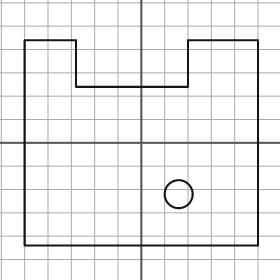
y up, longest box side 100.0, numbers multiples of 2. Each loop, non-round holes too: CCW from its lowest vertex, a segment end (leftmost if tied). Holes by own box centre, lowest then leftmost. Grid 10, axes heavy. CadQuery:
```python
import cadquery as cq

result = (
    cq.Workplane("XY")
    .moveTo(-50.0, -44.0)
    .lineTo(50.0, -44.0)
    .lineTo(50.0, 44.0)
    .lineTo(20.0, 44.0)
    .lineTo(20.0, 24.0)
    .lineTo(-28.0, 24.0)
    .lineTo(-28.0, 44.0)
    .lineTo(-50.0, 44.0)
    .close()
    .moveTo(16.0, -22.0)
    .circle(6.0)
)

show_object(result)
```